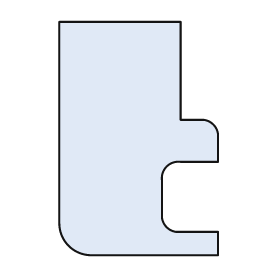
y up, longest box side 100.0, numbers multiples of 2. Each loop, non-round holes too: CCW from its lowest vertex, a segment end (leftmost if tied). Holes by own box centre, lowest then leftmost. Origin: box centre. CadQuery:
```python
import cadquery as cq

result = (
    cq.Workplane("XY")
    .moveTo(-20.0, -50.0)
    .lineTo(34.0, -50.0)
    .lineTo(34.0, -40.0)
    .lineTo(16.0, -40.0)
    .threePointArc((12.0, -38.0), (10.0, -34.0))
    .lineTo(10.0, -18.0)
    .threePointArc((12.0, -12.0), (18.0, -10.0))
    .lineTo(34.0, -10.0)
    .lineTo(34.0, 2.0)
    .threePointArc((32.0, 6.0), (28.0, 8.0))
    .lineTo(18.0, 8.0)
    .lineTo(18.0, 50.0)
    .lineTo(-34.0, 50.0)
    .lineTo(-34.0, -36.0)
    .threePointArc((-30.0, -46.0), (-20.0, -50.0))
    .close()
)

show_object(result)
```